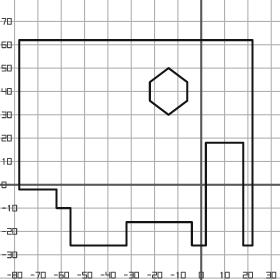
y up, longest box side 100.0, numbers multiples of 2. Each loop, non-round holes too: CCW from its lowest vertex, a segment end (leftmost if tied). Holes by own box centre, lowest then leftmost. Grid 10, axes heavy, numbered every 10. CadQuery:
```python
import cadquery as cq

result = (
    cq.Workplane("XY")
    .moveTo(-56.0, -26.0)
    .lineTo(-32.0, -26.0)
    .lineTo(-32.0, -16.0)
    .lineTo(-4.0, -16.0)
    .lineTo(-4.0, -26.0)
    .lineTo(2.0, -26.0)
    .lineTo(2.0, 18.0)
    .lineTo(18.0, 18.0)
    .lineTo(18.0, -26.0)
    .lineTo(22.0, -26.0)
    .lineTo(22.0, 62.0)
    .lineTo(-78.0, 62.0)
    .lineTo(-78.0, -2.0)
    .lineTo(-62.0, -2.0)
    .lineTo(-62.0, -10.0)
    .lineTo(-56.0, -10.0)
    .close()
    .moveTo(-14.0, 30.0)
    .lineTo(-6.0, 36.0)
    .lineTo(-6.0, 44.0)
    .lineTo(-14.0, 50.0)
    .lineTo(-22.0, 44.0)
    .lineTo(-22.0, 36.0)
    .close()
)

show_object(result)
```